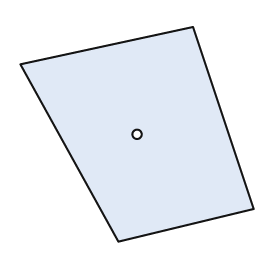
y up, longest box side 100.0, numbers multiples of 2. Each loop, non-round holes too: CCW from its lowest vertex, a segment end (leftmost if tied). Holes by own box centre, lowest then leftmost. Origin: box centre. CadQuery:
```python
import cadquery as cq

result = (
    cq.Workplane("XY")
    .moveTo(-8.0, -46.0)
    .lineTo(50.0, -32.0)
    .lineTo(24.0, 46.0)
    .lineTo(-50.0, 30.0)
    .close()
    .moveTo(0.0, 0.0)
    .circle(2.0)
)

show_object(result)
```